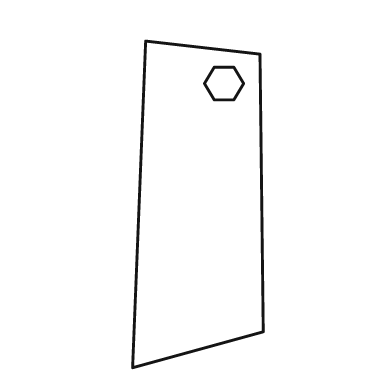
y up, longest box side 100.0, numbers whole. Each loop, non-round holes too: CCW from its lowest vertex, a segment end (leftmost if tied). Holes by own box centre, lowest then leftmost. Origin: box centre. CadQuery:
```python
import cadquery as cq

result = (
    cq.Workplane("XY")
    .moveTo(-20.0, -50.0)
    .lineTo(20.0, -39.0)
    .lineTo(19.0, 46.0)
    .lineTo(-16.0, 50.0)
    .close()
    .moveTo(5.0, 32.0)
    .lineTo(11.0, 32.0)
    .lineTo(14.0, 37.0)
    .lineTo(11.0, 42.0)
    .lineTo(5.0, 42.0)
    .lineTo(2.0, 37.0)
    .close()
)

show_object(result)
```